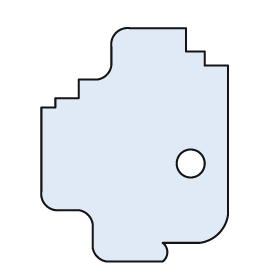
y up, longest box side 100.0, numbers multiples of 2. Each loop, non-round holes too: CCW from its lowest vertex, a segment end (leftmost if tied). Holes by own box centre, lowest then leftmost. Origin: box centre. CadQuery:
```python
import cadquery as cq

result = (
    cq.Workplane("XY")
    .moveTo(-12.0, -50.0)
    .lineTo(12.0, -50.0)
    .threePointArc((14.0, -46.0), (12.0, -42.0))
    .lineTo(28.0, -42.0)
    .threePointArc((36.0, -38.0), (40.0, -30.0))
    .lineTo(40.0, 34.0)
    .lineTo(30.0, 34.0)
    .lineTo(30.0, 40.0)
    .lineTo(22.0, 40.0)
    .lineTo(22.0, 50.0)
    .lineTo(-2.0, 50.0)
    .threePointArc((-8.0, 48.0), (-10.0, 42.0))
    .lineTo(-10.0, 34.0)
    .threePointArc((-12.0, 30.0), (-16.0, 28.0))
    .lineTo(-24.0, 28.0)
    .lineTo(-24.0, 20.0)
    .lineTo(-34.0, 20.0)
    .lineTo(-34.0, 16.0)
    .lineTo(-40.0, 16.0)
    .lineTo(-40.0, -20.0)
    .threePointArc((-38.0, -26.0), (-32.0, -28.0))
    .lineTo(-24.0, -28.0)
    .threePointArc((-20.0, -30.0), (-18.0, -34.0))
    .lineTo(-18.0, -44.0)
    .threePointArc((-16.0, -48.0), (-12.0, -50.0))
    .close()
    .moveTo(24.0, -8.0)
    .circle(6.0)
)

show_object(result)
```